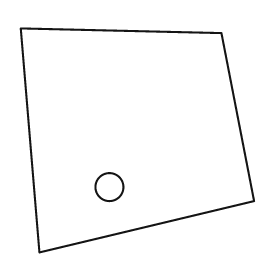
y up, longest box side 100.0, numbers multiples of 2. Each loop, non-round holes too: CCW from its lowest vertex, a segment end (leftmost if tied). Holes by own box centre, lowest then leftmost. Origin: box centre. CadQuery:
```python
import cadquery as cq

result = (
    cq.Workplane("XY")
    .moveTo(-42.0, -48.0)
    .lineTo(50.0, -26.0)
    .lineTo(36.0, 46.0)
    .lineTo(-50.0, 48.0)
    .close()
    .moveTo(-12.0, -20.0)
    .circle(6.0)
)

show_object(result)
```